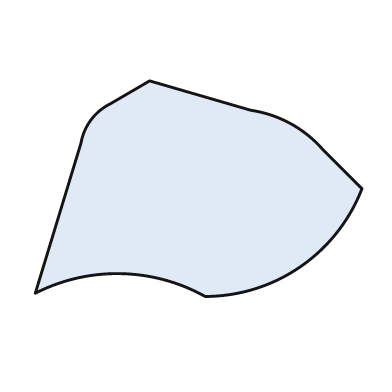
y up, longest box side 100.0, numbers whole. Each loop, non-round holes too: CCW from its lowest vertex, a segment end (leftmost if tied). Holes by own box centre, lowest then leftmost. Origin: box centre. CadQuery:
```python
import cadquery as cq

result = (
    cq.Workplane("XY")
    .moveTo(2.0, -33.0)
    .threePointArc((31.0, -24.0), (50.0, 0.0))
    .lineTo(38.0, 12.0)
    .threePointArc((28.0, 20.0), (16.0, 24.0))
    .lineTo(-15.0, 33.0)
    .lineTo(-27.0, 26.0)
    .threePointArc((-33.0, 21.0), (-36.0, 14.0))
    .lineTo(-50.0, -32.0)
    .threePointArc((-24.0, -26.0), (2.0, -33.0))
    .close()
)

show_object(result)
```